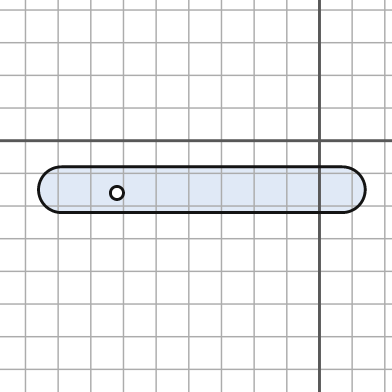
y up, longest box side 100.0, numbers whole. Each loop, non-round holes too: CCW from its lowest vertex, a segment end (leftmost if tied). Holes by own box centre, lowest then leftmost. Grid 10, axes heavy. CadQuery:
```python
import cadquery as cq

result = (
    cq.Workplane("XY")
    .moveTo(-79.0, -22.0)
    .lineTo(7.0, -22.0)
    .threePointArc((14.0, -15.0), (7.0, -8.0))
    .lineTo(-79.0, -8.0)
    .threePointArc((-86.0, -15.0), (-79.0, -22.0))
    .close()
    .moveTo(-62.0, -16.0)
    .circle(2.0)
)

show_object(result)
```